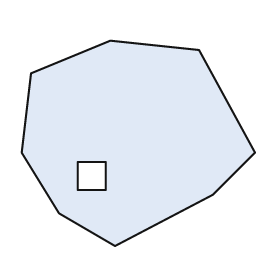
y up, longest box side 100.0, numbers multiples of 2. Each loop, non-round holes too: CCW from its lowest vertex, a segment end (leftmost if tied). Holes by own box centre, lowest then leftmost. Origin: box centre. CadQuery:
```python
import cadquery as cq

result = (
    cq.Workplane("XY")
    .moveTo(-10.0, -44.0)
    .lineTo(32.0, -22.0)
    .lineTo(50.0, -4.0)
    .lineTo(26.0, 40.0)
    .lineTo(-12.0, 44.0)
    .lineTo(-46.0, 30.0)
    .lineTo(-50.0, -4.0)
    .lineTo(-34.0, -30.0)
    .close()
    .moveTo(-26.0, -20.0)
    .lineTo(-14.0, -20.0)
    .lineTo(-14.0, -8.0)
    .lineTo(-26.0, -8.0)
    .close()
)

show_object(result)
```